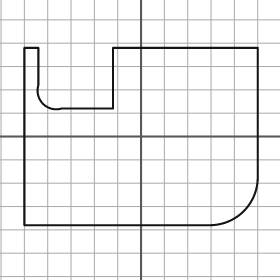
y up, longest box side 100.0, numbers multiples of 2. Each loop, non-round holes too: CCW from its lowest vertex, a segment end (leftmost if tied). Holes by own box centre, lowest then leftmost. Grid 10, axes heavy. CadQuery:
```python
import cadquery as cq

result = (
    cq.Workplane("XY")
    .moveTo(-50.0, -38.0)
    .lineTo(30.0, -38.0)
    .threePointArc((44.0, -32.0), (50.0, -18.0))
    .lineTo(50.0, 38.0)
    .lineTo(-12.0, 38.0)
    .lineTo(-12.0, 12.0)
    .lineTo(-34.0, 12.0)
    .threePointArc((-42.0, 14.0), (-44.0, 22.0))
    .lineTo(-44.0, 38.0)
    .lineTo(-50.0, 38.0)
    .close()
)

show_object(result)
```